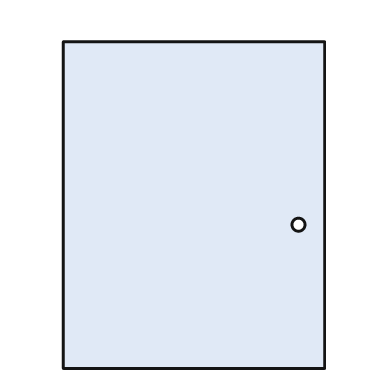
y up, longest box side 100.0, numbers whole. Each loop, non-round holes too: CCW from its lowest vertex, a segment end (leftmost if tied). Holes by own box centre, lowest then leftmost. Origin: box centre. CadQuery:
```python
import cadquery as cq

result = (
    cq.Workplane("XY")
    .moveTo(-40.0, -50.0)
    .lineTo(40.0, -50.0)
    .lineTo(40.0, 50.0)
    .lineTo(-40.0, 50.0)
    .close()
    .moveTo(32.0, -6.0)
    .circle(2.0)
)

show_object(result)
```